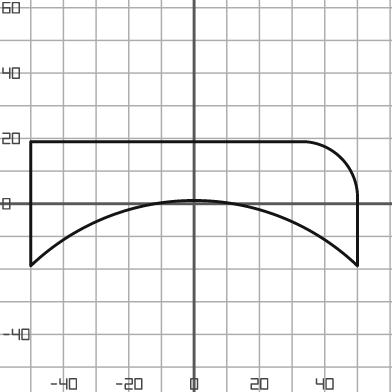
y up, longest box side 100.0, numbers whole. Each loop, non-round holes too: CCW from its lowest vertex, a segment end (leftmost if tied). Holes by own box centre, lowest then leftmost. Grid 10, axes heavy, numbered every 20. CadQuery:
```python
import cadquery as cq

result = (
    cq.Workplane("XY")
    .moveTo(-50.0, -19.0)
    .threePointArc((0.0, 1.0), (50.0, -19.0))
    .lineTo(50.0, 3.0)
    .threePointArc((45.0, 14.0), (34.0, 19.0))
    .lineTo(-50.0, 19.0)
    .close()
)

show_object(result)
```